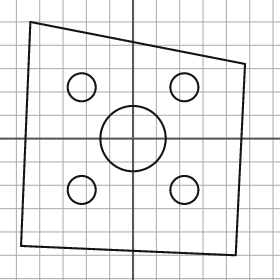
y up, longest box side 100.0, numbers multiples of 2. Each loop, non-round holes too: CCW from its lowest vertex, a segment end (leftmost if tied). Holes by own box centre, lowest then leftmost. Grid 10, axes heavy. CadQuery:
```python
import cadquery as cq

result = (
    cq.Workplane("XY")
    .moveTo(44.0, -50.0)
    .lineTo(48.0, 32.0)
    .lineTo(-44.0, 50.0)
    .lineTo(-48.0, -46.0)
    .close()
    .moveTo(-22.0, -22.0)
    .circle(6.0)
    .moveTo(22.0, -22.0)
    .circle(6.0)
    .moveTo(0.0, 0.0)
    .circle(14.0)
    .moveTo(-22.0, 22.0)
    .circle(6.0)
    .moveTo(22.0, 22.0)
    .circle(6.0)
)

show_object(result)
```